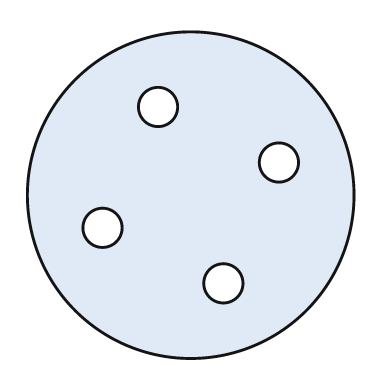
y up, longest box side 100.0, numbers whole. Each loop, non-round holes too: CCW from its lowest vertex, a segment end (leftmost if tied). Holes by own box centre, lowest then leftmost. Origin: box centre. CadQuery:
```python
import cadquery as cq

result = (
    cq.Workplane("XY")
    .moveTo(0.0, 0.0)
    .circle(50.0)
    .moveTo(10.0, -27.0)
    .circle(6.0)
    .moveTo(-27.0, -10.0)
    .circle(6.0)
    .moveTo(27.0, 10.0)
    .circle(6.0)
    .moveTo(-10.0, 27.0)
    .circle(6.0)
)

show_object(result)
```